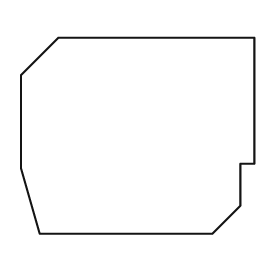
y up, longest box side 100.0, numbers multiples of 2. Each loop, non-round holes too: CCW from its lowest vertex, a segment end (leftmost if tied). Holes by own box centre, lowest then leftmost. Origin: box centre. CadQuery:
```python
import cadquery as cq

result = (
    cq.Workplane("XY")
    .moveTo(-42.0, -42.0)
    .lineTo(32.0, -42.0)
    .lineTo(44.0, -30.0)
    .lineTo(44.0, -12.0)
    .lineTo(50.0, -12.0)
    .lineTo(50.0, 42.0)
    .lineTo(-34.0, 42.0)
    .lineTo(-50.0, 26.0)
    .lineTo(-50.0, -14.0)
    .close()
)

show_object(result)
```